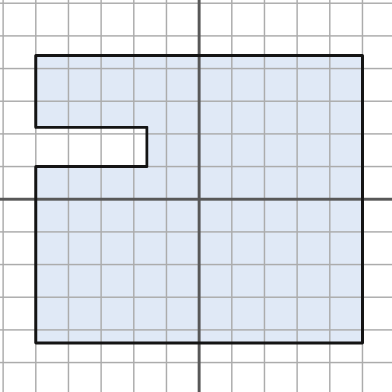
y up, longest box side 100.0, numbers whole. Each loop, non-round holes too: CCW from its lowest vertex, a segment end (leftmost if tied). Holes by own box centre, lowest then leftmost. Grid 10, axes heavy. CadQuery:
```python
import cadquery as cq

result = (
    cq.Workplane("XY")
    .moveTo(-50.0, -44.0)
    .lineTo(50.0, -44.0)
    .lineTo(50.0, 44.0)
    .lineTo(-50.0, 44.0)
    .lineTo(-50.0, 22.0)
    .lineTo(-16.0, 22.0)
    .lineTo(-16.0, 10.0)
    .lineTo(-50.0, 10.0)
    .close()
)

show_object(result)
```